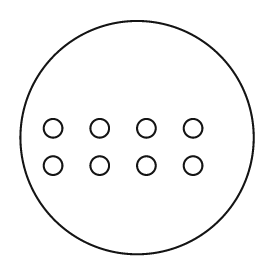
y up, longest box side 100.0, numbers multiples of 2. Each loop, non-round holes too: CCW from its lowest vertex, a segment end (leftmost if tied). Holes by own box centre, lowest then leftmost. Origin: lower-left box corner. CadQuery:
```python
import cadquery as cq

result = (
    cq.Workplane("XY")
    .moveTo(50.0, 50.0)
    .circle(50.0)
    .moveTo(14.0, 38.0)
    .circle(4.0)
    .moveTo(34.0, 38.0)
    .circle(4.0)
    .moveTo(54.0, 38.0)
    .circle(4.0)
    .moveTo(74.0, 38.0)
    .circle(4.0)
    .moveTo(14.0, 54.0)
    .circle(4.0)
    .moveTo(34.0, 54.0)
    .circle(4.0)
    .moveTo(54.0, 54.0)
    .circle(4.0)
    .moveTo(74.0, 54.0)
    .circle(4.0)
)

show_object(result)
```